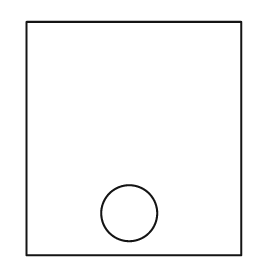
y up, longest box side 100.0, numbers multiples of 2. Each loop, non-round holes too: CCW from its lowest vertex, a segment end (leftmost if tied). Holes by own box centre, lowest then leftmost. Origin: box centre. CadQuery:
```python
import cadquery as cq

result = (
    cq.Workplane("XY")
    .moveTo(-46.0, -50.0)
    .lineTo(46.0, -50.0)
    .lineTo(46.0, 50.0)
    .lineTo(-46.0, 50.0)
    .close()
    .moveTo(-2.0, -32.0)
    .circle(12.0)
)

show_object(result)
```